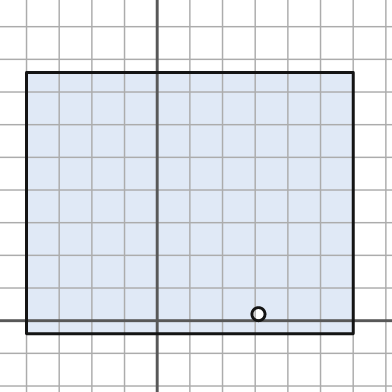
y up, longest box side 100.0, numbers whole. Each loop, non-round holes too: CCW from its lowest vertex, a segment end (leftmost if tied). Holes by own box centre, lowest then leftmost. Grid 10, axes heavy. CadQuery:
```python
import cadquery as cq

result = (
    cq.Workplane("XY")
    .moveTo(-40.0, -4.0)
    .lineTo(60.0, -4.0)
    .lineTo(60.0, 76.0)
    .lineTo(-40.0, 76.0)
    .close()
    .moveTo(31.0, 2.0)
    .circle(2.0)
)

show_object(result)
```